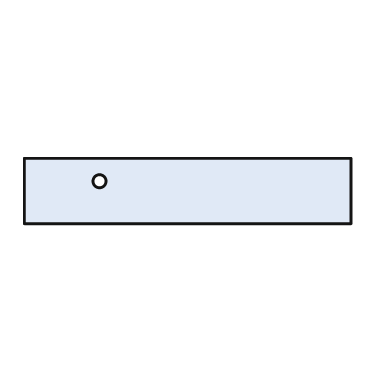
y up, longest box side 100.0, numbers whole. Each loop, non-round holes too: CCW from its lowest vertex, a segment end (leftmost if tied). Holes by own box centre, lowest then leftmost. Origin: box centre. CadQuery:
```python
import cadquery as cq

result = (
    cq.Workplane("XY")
    .moveTo(-50.0, -10.0)
    .lineTo(50.0, -10.0)
    .lineTo(50.0, 10.0)
    .lineTo(-50.0, 10.0)
    .close()
    .moveTo(-27.0, 3.0)
    .circle(2.0)
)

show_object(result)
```